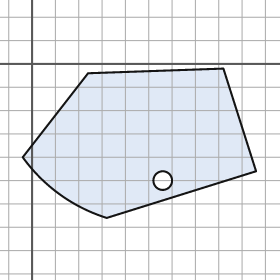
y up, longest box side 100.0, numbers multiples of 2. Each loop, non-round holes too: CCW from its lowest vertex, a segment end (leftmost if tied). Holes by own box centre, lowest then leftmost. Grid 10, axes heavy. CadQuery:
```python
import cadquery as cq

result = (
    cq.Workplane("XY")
    .moveTo(32.0, -66.0)
    .lineTo(96.0, -46.0)
    .lineTo(82.0, -2.0)
    .lineTo(24.0, -4.0)
    .lineTo(-4.0, -40.0)
    .threePointArc((12.0, -56.0), (32.0, -66.0))
    .close()
    .moveTo(56.0, -50.0)
    .circle(4.0)
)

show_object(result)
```